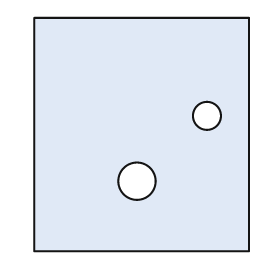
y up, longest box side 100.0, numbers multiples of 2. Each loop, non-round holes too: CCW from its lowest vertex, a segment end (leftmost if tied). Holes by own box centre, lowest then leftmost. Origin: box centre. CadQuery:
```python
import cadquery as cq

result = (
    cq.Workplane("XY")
    .moveTo(-46.0, -50.0)
    .lineTo(46.0, -50.0)
    .lineTo(46.0, 50.0)
    .lineTo(-46.0, 50.0)
    .close()
    .moveTo(-2.0, -20.0)
    .circle(8.0)
    .moveTo(28.0, 8.0)
    .circle(6.0)
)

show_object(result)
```